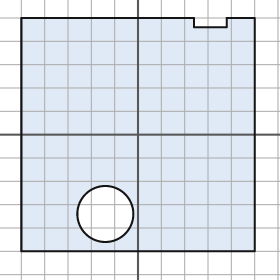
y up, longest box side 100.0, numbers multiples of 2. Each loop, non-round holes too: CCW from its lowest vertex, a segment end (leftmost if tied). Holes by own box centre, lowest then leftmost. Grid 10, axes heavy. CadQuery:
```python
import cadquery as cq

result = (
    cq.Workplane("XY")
    .moveTo(-50.0, -50.0)
    .lineTo(50.0, -50.0)
    .lineTo(50.0, 50.0)
    .lineTo(38.0, 50.0)
    .lineTo(38.0, 46.0)
    .lineTo(24.0, 46.0)
    .lineTo(24.0, 50.0)
    .lineTo(-50.0, 50.0)
    .close()
    .moveTo(-14.0, -34.0)
    .circle(12.0)
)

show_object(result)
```